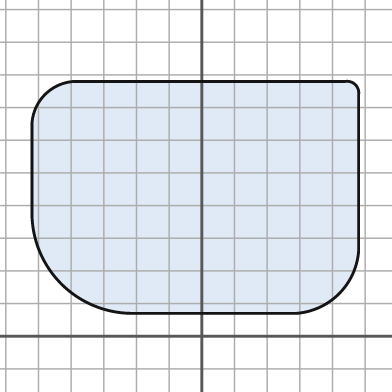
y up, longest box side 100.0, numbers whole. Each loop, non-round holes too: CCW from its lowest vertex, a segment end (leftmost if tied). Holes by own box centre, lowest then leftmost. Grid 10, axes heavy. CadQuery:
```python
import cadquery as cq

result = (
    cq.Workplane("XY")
    .moveTo(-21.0, 7.0)
    .lineTo(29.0, 7.0)
    .threePointArc((42.0, 13.0), (48.0, 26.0))
    .lineTo(48.0, 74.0)
    .threePointArc((47.0, 77.0), (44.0, 78.0))
    .lineTo(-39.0, 78.0)
    .threePointArc((-48.0, 74.0), (-52.0, 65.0))
    .lineTo(-52.0, 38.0)
    .threePointArc((-43.0, 16.0), (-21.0, 7.0))
    .close()
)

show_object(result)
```